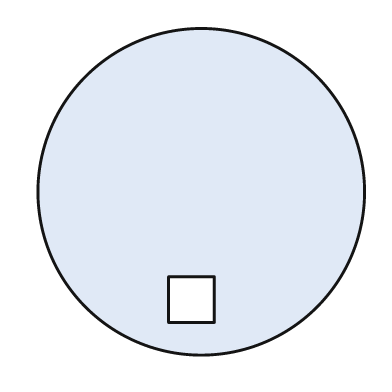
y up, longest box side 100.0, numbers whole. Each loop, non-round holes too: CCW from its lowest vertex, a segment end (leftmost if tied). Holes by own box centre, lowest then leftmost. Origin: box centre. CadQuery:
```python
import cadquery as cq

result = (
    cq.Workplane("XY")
    .moveTo(0.0, 0.0)
    .circle(50.0)
    .moveTo(-10.0, -40.0)
    .lineTo(4.0, -40.0)
    .lineTo(4.0, -26.0)
    .lineTo(-10.0, -26.0)
    .close()
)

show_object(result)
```